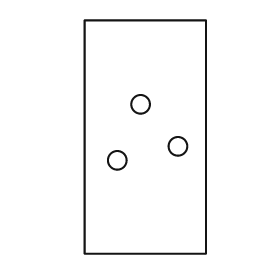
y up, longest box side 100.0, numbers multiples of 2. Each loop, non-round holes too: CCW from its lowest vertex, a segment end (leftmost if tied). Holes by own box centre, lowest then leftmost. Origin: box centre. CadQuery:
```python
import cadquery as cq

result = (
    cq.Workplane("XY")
    .moveTo(-26.0, -50.0)
    .lineTo(26.0, -50.0)
    .lineTo(26.0, 50.0)
    .lineTo(-26.0, 50.0)
    .close()
    .moveTo(-12.0, -10.0)
    .circle(4.0)
    .moveTo(14.0, -4.0)
    .circle(4.0)
    .moveTo(-2.0, 14.0)
    .circle(4.0)
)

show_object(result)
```